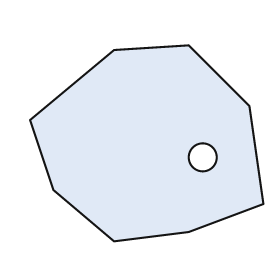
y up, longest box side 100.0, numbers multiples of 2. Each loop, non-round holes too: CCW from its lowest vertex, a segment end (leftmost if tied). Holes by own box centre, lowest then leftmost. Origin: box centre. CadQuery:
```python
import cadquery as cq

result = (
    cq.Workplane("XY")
    .moveTo(-14.0, -42.0)
    .lineTo(18.0, -38.0)
    .lineTo(50.0, -26.0)
    .lineTo(44.0, 16.0)
    .lineTo(18.0, 42.0)
    .lineTo(-14.0, 40.0)
    .lineTo(-50.0, 10.0)
    .lineTo(-40.0, -20.0)
    .close()
    .moveTo(24.0, -6.0)
    .circle(6.0)
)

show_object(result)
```